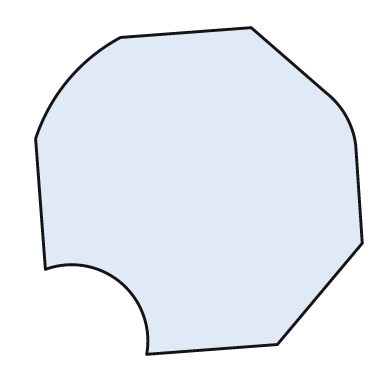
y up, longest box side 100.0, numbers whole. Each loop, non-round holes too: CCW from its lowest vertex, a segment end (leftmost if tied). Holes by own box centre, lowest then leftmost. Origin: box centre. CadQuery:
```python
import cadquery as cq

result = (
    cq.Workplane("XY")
    .moveTo(-16.0, -50.0)
    .lineTo(24.0, -47.0)
    .lineTo(50.0, -16.0)
    .lineTo(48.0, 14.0)
    .threePointArc((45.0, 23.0), (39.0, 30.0))
    .lineTo(16.0, 50.0)
    .lineTo(-24.0, 47.0)
    .threePointArc((-40.0, 34.0), (-50.0, 16.0))
    .lineTo(-47.0, -24.0)
    .threePointArc((-24.0, -28.0), (-16.0, -50.0))
    .close()
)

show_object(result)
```